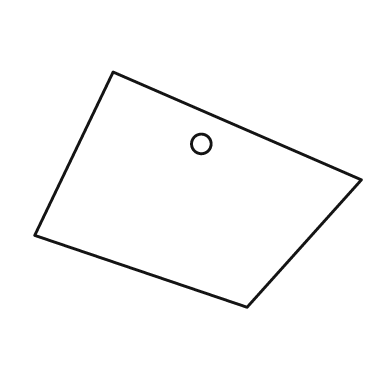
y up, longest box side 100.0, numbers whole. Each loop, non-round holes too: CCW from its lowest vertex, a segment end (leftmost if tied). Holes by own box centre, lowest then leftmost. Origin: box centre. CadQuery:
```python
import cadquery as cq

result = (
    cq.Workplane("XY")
    .moveTo(15.0, -36.0)
    .lineTo(50.0, 3.0)
    .lineTo(-26.0, 36.0)
    .lineTo(-50.0, -14.0)
    .close()
    .moveTo(1.0, 14.0)
    .circle(3.0)
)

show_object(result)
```